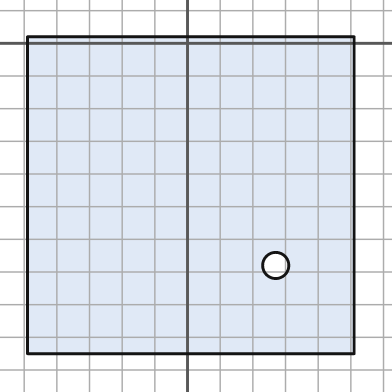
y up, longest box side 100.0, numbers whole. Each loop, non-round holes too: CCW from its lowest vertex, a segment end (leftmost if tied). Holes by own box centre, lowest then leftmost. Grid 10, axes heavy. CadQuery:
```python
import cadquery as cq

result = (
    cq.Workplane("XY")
    .moveTo(-49.0, -95.0)
    .lineTo(51.0, -95.0)
    .lineTo(51.0, 2.0)
    .lineTo(-49.0, 2.0)
    .close()
    .moveTo(27.0, -68.0)
    .circle(4.0)
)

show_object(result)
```